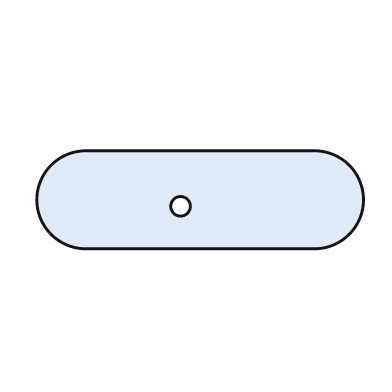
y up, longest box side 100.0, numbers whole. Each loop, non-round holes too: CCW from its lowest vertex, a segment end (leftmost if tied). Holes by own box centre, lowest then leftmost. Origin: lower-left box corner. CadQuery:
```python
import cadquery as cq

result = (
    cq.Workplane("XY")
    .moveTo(15.0, 0.0)
    .lineTo(85.0, 0.0)
    .threePointArc((100.0, 15.0), (85.0, 30.0))
    .lineTo(15.0, 30.0)
    .threePointArc((0.0, 15.0), (15.0, 0.0))
    .close()
    .moveTo(44.0, 13.0)
    .circle(3.0)
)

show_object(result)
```